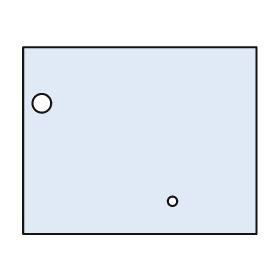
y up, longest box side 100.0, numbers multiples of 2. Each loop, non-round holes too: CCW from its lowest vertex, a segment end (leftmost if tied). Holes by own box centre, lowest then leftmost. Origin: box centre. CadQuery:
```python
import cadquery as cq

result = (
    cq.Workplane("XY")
    .moveTo(-50.0, -40.0)
    .lineTo(50.0, -40.0)
    .lineTo(50.0, 40.0)
    .lineTo(-50.0, 40.0)
    .close()
    .moveTo(14.0, -26.0)
    .circle(2.0)
    .moveTo(-42.0, 16.0)
    .circle(4.0)
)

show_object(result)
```